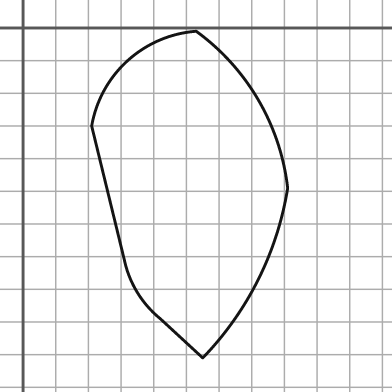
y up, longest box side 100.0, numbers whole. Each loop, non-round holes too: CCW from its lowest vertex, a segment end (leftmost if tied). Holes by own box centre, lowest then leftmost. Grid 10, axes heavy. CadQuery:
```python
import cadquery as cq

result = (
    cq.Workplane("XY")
    .moveTo(55.0, -101.0)
    .threePointArc((72.0, -77.0), (81.0, -49.0))
    .threePointArc((72.0, -22.0), (53.0, -1.0))
    .threePointArc((32.0, -10.0), (21.0, -30.0))
    .lineTo(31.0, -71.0)
    .threePointArc((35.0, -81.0), (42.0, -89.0))
    .close()
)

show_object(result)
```